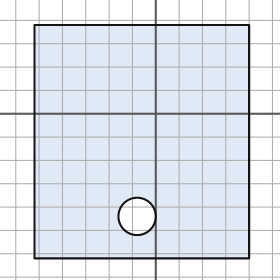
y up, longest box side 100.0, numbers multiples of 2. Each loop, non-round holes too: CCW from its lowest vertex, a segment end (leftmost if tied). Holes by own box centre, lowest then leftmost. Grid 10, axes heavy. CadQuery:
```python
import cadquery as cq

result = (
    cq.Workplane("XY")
    .moveTo(-52.0, -62.0)
    .lineTo(40.0, -62.0)
    .lineTo(40.0, 38.0)
    .lineTo(-52.0, 38.0)
    .close()
    .moveTo(-8.0, -44.0)
    .circle(8.0)
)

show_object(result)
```